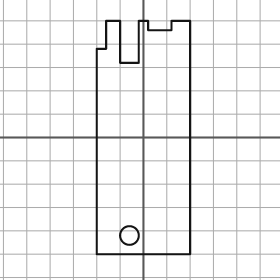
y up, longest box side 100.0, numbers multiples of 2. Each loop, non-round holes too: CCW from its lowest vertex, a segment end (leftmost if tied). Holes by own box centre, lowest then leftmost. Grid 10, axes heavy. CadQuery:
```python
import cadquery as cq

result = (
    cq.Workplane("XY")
    .moveTo(-20.0, -50.0)
    .lineTo(20.0, -50.0)
    .lineTo(20.0, 50.0)
    .lineTo(12.0, 50.0)
    .lineTo(12.0, 46.0)
    .lineTo(2.0, 46.0)
    .lineTo(2.0, 50.0)
    .lineTo(-2.0, 50.0)
    .lineTo(-2.0, 32.0)
    .lineTo(-10.0, 32.0)
    .lineTo(-10.0, 50.0)
    .lineTo(-16.0, 50.0)
    .lineTo(-16.0, 38.0)
    .lineTo(-20.0, 38.0)
    .close()
    .moveTo(-6.0, -42.0)
    .circle(4.0)
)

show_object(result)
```